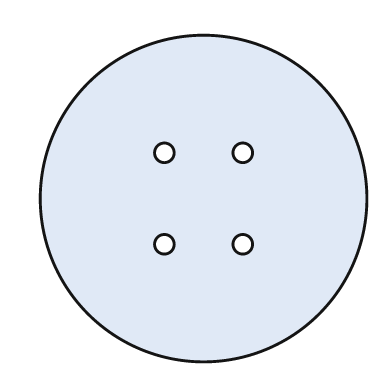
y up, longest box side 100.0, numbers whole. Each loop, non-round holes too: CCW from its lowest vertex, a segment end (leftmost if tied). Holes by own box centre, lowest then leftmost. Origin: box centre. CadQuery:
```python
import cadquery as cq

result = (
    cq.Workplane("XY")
    .moveTo(0.0, 0.0)
    .circle(50.0)
    .moveTo(-12.0, -14.0)
    .circle(3.0)
    .moveTo(12.0, -14.0)
    .circle(3.0)
    .moveTo(-12.0, 14.0)
    .circle(3.0)
    .moveTo(12.0, 14.0)
    .circle(3.0)
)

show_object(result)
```